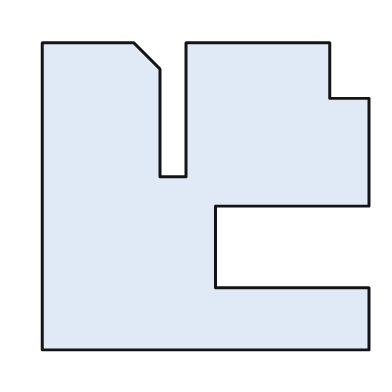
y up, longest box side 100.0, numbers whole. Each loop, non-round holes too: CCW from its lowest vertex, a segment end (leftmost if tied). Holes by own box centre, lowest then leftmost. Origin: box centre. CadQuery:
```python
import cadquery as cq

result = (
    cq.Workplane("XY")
    .moveTo(-50.0, -47.0)
    .lineTo(50.0, -47.0)
    .lineTo(50.0, -28.0)
    .lineTo(3.0, -28.0)
    .lineTo(3.0, -3.0)
    .lineTo(50.0, -3.0)
    .lineTo(50.0, 30.0)
    .lineTo(38.0, 30.0)
    .lineTo(38.0, 47.0)
    .lineTo(-6.0, 47.0)
    .lineTo(-6.0, 6.0)
    .lineTo(-14.0, 6.0)
    .lineTo(-14.0, 39.0)
    .lineTo(-22.0, 47.0)
    .lineTo(-50.0, 47.0)
    .close()
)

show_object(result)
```